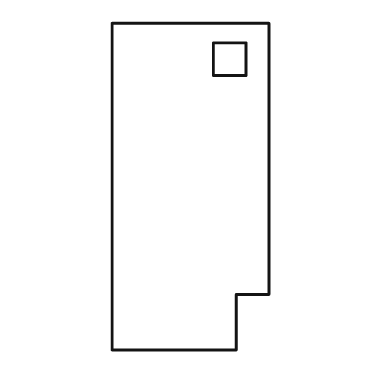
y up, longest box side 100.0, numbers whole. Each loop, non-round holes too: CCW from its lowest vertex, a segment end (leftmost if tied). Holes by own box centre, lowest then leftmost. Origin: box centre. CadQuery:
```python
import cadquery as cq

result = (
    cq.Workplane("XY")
    .moveTo(-24.0, -50.0)
    .lineTo(14.0, -50.0)
    .lineTo(14.0, -33.0)
    .lineTo(24.0, -33.0)
    .lineTo(24.0, 50.0)
    .lineTo(-24.0, 50.0)
    .close()
    .moveTo(7.0, 34.0)
    .lineTo(17.0, 34.0)
    .lineTo(17.0, 44.0)
    .lineTo(7.0, 44.0)
    .close()
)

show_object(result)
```